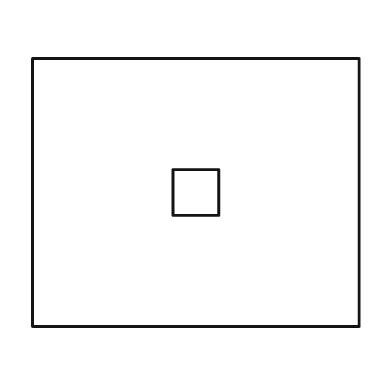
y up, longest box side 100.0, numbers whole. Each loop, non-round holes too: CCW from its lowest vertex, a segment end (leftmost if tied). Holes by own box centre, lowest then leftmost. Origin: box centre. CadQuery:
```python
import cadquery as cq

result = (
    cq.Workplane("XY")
    .moveTo(-50.0, -41.0)
    .lineTo(50.0, -41.0)
    .lineTo(50.0, 41.0)
    .lineTo(-50.0, 41.0)
    .close()
    .moveTo(-7.0, -7.0)
    .lineTo(7.0, -7.0)
    .lineTo(7.0, 7.0)
    .lineTo(-7.0, 7.0)
    .close()
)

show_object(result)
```